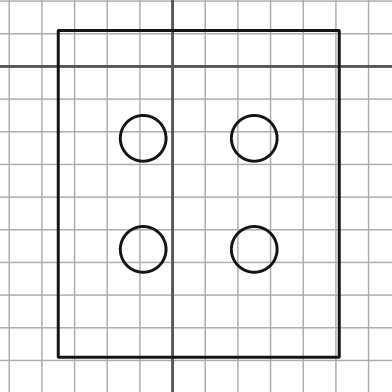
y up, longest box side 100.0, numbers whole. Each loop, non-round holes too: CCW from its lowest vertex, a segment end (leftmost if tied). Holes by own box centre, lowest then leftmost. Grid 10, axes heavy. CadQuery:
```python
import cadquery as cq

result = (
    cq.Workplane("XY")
    .moveTo(-35.0, -89.0)
    .lineTo(51.0, -89.0)
    .lineTo(51.0, 11.0)
    .lineTo(-35.0, 11.0)
    .close()
    .moveTo(-9.0, -56.0)
    .circle(7.0)
    .moveTo(25.0, -56.0)
    .circle(7.0)
    .moveTo(-9.0, -22.0)
    .circle(7.0)
    .moveTo(25.0, -22.0)
    .circle(7.0)
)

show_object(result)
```